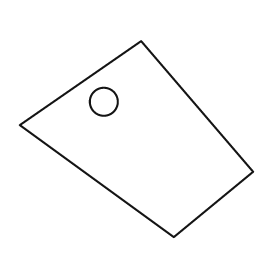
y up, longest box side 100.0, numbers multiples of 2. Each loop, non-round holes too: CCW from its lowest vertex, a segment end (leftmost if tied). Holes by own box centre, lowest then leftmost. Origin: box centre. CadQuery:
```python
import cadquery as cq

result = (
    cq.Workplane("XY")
    .moveTo(16.0, -42.0)
    .lineTo(50.0, -14.0)
    .lineTo(2.0, 42.0)
    .lineTo(-50.0, 6.0)
    .close()
    .moveTo(-14.0, 16.0)
    .circle(6.0)
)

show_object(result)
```